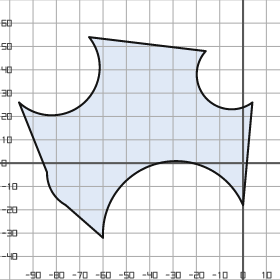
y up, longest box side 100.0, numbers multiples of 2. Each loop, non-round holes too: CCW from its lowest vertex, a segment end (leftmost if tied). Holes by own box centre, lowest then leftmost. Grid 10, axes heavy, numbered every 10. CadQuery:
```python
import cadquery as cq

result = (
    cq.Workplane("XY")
    .moveTo(-60.0, -32.0)
    .threePointArc((-36.0, 0.0), (0.0, -18.0))
    .lineTo(4.0, 26.0)
    .threePointArc((-16.0, 28.0), (-16.0, 48.0))
    .lineTo(-66.0, 54.0)
    .threePointArc((-68.0, 26.0), (-96.0, 26.0))
    .lineTo(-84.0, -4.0)
    .threePointArc((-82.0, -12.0), (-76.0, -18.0))
    .close()
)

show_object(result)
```